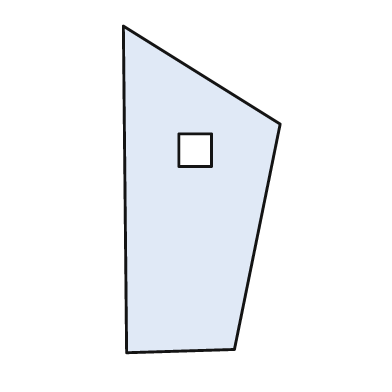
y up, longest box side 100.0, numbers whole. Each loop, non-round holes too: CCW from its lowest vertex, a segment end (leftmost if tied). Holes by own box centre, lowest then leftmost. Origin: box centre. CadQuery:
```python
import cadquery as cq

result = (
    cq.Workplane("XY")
    .moveTo(-23.0, -50.0)
    .lineTo(10.0, -49.0)
    .lineTo(24.0, 20.0)
    .lineTo(-24.0, 50.0)
    .close()
    .moveTo(-7.0, 7.0)
    .lineTo(3.0, 7.0)
    .lineTo(3.0, 17.0)
    .lineTo(-7.0, 17.0)
    .close()
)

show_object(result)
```